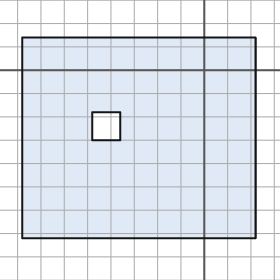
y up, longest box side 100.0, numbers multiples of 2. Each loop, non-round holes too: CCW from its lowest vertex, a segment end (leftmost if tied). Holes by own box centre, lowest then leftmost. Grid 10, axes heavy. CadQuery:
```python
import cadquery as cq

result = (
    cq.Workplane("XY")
    .moveTo(-78.0, -72.0)
    .lineTo(22.0, -72.0)
    .lineTo(22.0, 14.0)
    .lineTo(-78.0, 14.0)
    .close()
    .moveTo(-48.0, -30.0)
    .lineTo(-36.0, -30.0)
    .lineTo(-36.0, -18.0)
    .lineTo(-48.0, -18.0)
    .close()
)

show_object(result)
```